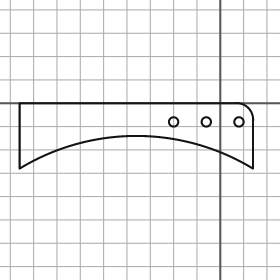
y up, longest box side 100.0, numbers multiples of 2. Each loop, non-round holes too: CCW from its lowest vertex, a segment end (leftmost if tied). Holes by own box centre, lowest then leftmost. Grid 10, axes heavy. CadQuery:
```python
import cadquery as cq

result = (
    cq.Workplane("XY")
    .moveTo(-86.0, -28.0)
    .threePointArc((-36.0, -14.0), (14.0, -28.0))
    .lineTo(14.0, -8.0)
    .threePointArc((12.0, -2.0), (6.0, 0.0))
    .lineTo(-86.0, 0.0)
    .close()
    .moveTo(-20.0, -8.0)
    .circle(2.0)
    .moveTo(-6.0, -8.0)
    .circle(2.0)
    .moveTo(8.0, -8.0)
    .circle(2.0)
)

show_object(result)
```